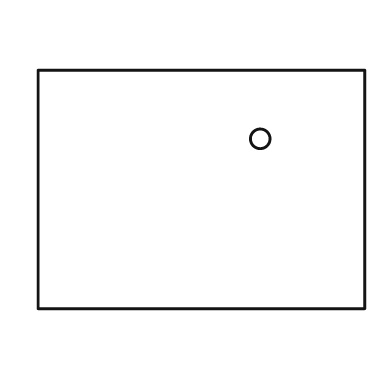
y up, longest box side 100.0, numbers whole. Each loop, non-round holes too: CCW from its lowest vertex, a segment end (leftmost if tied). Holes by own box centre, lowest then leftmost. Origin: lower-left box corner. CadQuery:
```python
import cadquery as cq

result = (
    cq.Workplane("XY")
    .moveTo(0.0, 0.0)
    .lineTo(100.0, 0.0)
    .lineTo(100.0, 73.0)
    .lineTo(0.0, 73.0)
    .close()
    .moveTo(68.0, 52.0)
    .circle(3.0)
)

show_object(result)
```